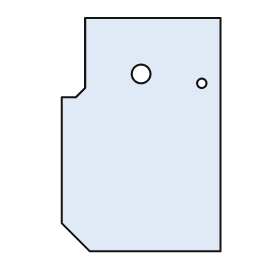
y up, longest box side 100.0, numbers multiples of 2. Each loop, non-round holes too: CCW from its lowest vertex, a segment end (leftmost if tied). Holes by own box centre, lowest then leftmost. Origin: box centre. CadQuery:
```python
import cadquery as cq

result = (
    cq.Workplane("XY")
    .moveTo(-22.0, -50.0)
    .lineTo(34.0, -50.0)
    .lineTo(34.0, 50.0)
    .lineTo(-24.0, 50.0)
    .lineTo(-24.0, 20.0)
    .lineTo(-28.0, 16.0)
    .lineTo(-34.0, 16.0)
    .lineTo(-34.0, -38.0)
    .close()
    .moveTo(26.0, 22.0)
    .circle(2.0)
    .moveTo(0.0, 26.0)
    .circle(4.0)
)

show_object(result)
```